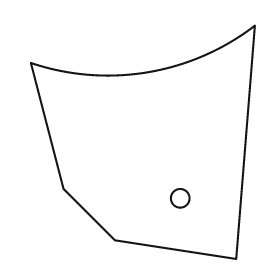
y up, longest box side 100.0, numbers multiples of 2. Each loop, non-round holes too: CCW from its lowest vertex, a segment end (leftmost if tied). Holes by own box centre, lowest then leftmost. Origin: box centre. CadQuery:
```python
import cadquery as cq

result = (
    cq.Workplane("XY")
    .moveTo(40.0, -50.0)
    .lineTo(48.0, 50.0)
    .threePointArc((2.0, 30.0), (-48.0, 34.0))
    .lineTo(-34.0, -20.0)
    .lineTo(-12.0, -42.0)
    .close()
    .moveTo(16.0, -24.0)
    .circle(4.0)
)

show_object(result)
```